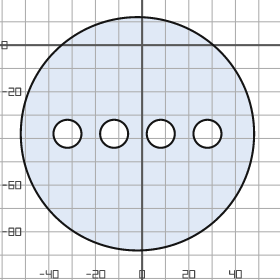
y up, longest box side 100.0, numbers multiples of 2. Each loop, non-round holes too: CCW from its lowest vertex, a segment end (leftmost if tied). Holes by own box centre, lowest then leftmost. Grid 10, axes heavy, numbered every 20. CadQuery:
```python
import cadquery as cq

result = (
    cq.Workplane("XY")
    .moveTo(-2.0, -38.0)
    .circle(50.0)
    .moveTo(-32.0, -38.0)
    .circle(6.0)
    .moveTo(-12.0, -38.0)
    .circle(6.0)
    .moveTo(8.0, -38.0)
    .circle(6.0)
    .moveTo(28.0, -38.0)
    .circle(6.0)
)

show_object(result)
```